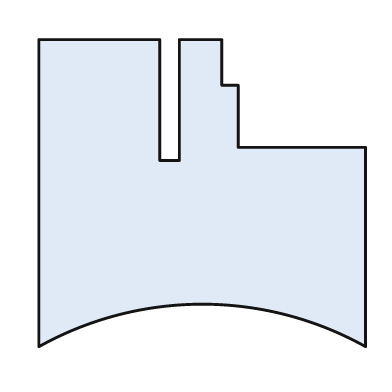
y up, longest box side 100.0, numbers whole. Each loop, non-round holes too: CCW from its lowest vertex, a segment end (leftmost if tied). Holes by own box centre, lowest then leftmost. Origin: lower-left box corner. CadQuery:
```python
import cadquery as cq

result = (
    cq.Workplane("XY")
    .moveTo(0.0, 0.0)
    .threePointArc((50.0, 13.0), (100.0, 0.0))
    .lineTo(100.0, 61.0)
    .lineTo(61.0, 61.0)
    .lineTo(61.0, 80.0)
    .lineTo(56.0, 80.0)
    .lineTo(56.0, 94.0)
    .lineTo(43.0, 94.0)
    .lineTo(43.0, 57.0)
    .lineTo(37.0, 57.0)
    .lineTo(37.0, 94.0)
    .lineTo(0.0, 94.0)
    .close()
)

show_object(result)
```